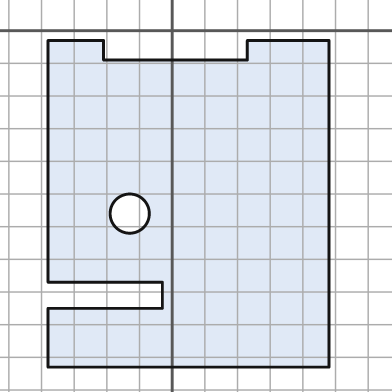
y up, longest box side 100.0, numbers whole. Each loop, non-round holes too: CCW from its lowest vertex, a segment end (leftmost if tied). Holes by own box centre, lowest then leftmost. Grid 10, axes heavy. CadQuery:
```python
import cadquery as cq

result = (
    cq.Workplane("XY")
    .moveTo(-38.0, -103.0)
    .lineTo(48.0, -103.0)
    .lineTo(48.0, -3.0)
    .lineTo(23.0, -3.0)
    .lineTo(23.0, -9.0)
    .lineTo(-21.0, -9.0)
    .lineTo(-21.0, -3.0)
    .lineTo(-38.0, -3.0)
    .lineTo(-38.0, -77.0)
    .lineTo(-3.0, -77.0)
    .lineTo(-3.0, -85.0)
    .lineTo(-38.0, -85.0)
    .close()
    .moveTo(-13.0, -56.0)
    .circle(6.0)
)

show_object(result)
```